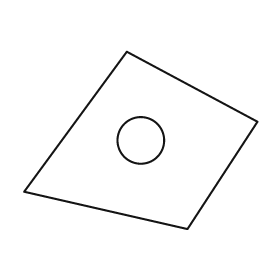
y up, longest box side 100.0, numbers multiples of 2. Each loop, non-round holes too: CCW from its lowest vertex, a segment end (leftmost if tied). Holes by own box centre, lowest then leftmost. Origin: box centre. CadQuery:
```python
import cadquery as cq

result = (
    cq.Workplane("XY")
    .moveTo(20.0, -38.0)
    .lineTo(50.0, 8.0)
    .lineTo(-6.0, 38.0)
    .lineTo(-50.0, -22.0)
    .close()
    .moveTo(0.0, 0.0)
    .circle(10.0)
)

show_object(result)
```